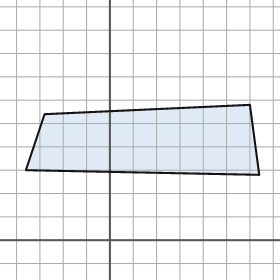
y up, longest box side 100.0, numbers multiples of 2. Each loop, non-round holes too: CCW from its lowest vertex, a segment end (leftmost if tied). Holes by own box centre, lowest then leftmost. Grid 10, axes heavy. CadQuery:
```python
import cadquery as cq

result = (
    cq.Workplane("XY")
    .moveTo(64.0, 28.0)
    .lineTo(60.0, 58.0)
    .lineTo(-28.0, 54.0)
    .lineTo(-36.0, 30.0)
    .close()
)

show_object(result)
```